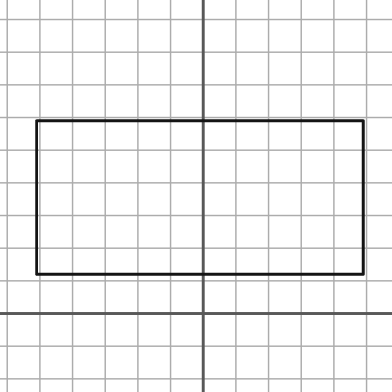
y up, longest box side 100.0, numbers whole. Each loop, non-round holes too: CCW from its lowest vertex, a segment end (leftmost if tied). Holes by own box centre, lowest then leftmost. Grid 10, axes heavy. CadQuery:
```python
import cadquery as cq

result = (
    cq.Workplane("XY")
    .moveTo(-51.0, 12.0)
    .lineTo(49.0, 12.0)
    .lineTo(49.0, 59.0)
    .lineTo(-51.0, 59.0)
    .close()
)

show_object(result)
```